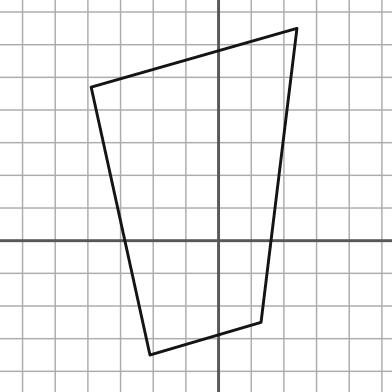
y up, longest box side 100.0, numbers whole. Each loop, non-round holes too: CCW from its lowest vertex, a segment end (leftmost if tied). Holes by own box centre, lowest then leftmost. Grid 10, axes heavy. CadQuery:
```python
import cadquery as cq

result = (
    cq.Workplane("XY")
    .moveTo(-21.0, -35.0)
    .lineTo(13.0, -25.0)
    .lineTo(24.0, 65.0)
    .lineTo(-39.0, 47.0)
    .close()
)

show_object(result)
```